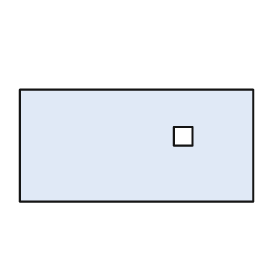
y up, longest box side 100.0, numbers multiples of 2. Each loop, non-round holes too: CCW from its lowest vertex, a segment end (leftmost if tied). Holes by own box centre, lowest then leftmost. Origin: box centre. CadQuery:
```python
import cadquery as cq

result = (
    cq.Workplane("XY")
    .moveTo(-50.0, -24.0)
    .lineTo(50.0, -24.0)
    .lineTo(50.0, 24.0)
    .lineTo(-50.0, 24.0)
    .close()
    .moveTo(16.0, 0.0)
    .lineTo(24.0, 0.0)
    .lineTo(24.0, 8.0)
    .lineTo(16.0, 8.0)
    .close()
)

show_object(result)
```